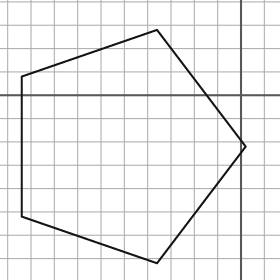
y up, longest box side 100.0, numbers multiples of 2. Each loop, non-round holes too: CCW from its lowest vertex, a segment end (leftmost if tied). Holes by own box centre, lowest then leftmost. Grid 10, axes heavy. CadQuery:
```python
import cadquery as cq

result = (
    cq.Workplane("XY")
    .moveTo(-36.0, -72.0)
    .lineTo(2.0, -22.0)
    .lineTo(-36.0, 28.0)
    .lineTo(-94.0, 8.0)
    .lineTo(-94.0, -52.0)
    .close()
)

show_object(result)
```